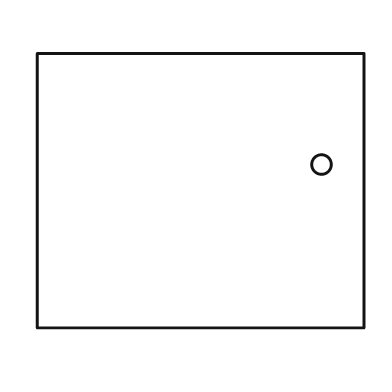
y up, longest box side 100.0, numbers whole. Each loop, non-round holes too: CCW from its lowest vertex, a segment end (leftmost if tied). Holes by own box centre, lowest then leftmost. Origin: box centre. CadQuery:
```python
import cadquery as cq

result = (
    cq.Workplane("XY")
    .moveTo(-50.0, -42.0)
    .lineTo(50.0, -42.0)
    .lineTo(50.0, 42.0)
    .lineTo(-50.0, 42.0)
    .close()
    .moveTo(37.0, 8.0)
    .circle(3.0)
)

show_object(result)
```